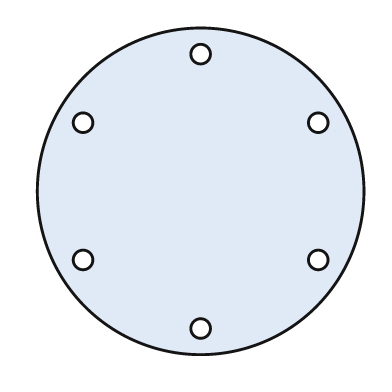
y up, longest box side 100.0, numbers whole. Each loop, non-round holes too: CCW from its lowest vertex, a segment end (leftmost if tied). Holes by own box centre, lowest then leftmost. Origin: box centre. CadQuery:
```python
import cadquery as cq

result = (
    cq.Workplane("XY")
    .moveTo(0.0, 0.0)
    .circle(50.0)
    .moveTo(0.0, -42.0)
    .circle(3.0)
    .moveTo(-36.0, -21.0)
    .circle(3.0)
    .moveTo(36.0, -21.0)
    .circle(3.0)
    .moveTo(-36.0, 21.0)
    .circle(3.0)
    .moveTo(36.0, 21.0)
    .circle(3.0)
    .moveTo(0.0, 42.0)
    .circle(3.0)
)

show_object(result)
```